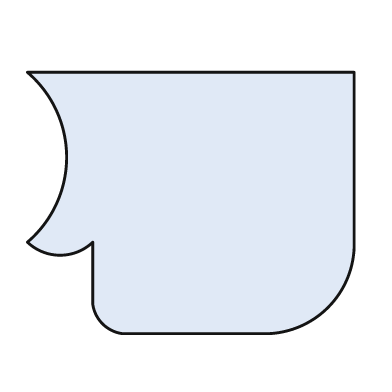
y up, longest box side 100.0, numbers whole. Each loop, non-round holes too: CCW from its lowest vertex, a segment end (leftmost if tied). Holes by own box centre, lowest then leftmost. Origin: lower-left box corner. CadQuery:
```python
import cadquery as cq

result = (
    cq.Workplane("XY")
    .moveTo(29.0, 0.0)
    .lineTo(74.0, 0.0)
    .threePointArc((92.0, 8.0), (100.0, 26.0))
    .lineTo(100.0, 80.0)
    .lineTo(0.0, 80.0)
    .threePointArc((12.0, 54.0), (0.0, 28.0))
    .threePointArc((10.0, 24.0), (20.0, 28.0))
    .lineTo(20.0, 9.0)
    .threePointArc((23.0, 3.0), (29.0, 0.0))
    .close()
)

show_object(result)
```